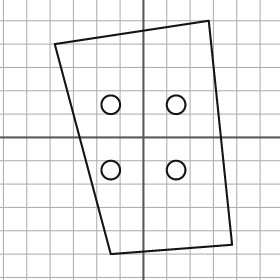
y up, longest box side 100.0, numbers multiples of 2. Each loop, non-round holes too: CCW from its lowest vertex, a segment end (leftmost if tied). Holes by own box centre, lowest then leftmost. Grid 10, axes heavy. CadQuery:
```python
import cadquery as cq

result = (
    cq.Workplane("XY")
    .moveTo(-14.0, -50.0)
    .lineTo(38.0, -46.0)
    .lineTo(28.0, 50.0)
    .lineTo(-38.0, 40.0)
    .close()
    .moveTo(-14.0, -14.0)
    .circle(4.0)
    .moveTo(14.0, -14.0)
    .circle(4.0)
    .moveTo(-14.0, 14.0)
    .circle(4.0)
    .moveTo(14.0, 14.0)
    .circle(4.0)
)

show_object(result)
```